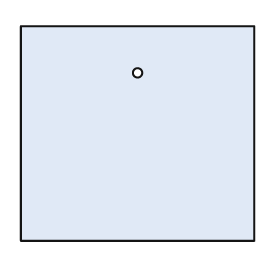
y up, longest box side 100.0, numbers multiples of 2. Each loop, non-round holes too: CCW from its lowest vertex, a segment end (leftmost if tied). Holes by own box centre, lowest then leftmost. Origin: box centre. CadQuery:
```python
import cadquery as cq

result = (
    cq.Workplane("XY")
    .moveTo(-50.0, -46.0)
    .lineTo(50.0, -46.0)
    .lineTo(50.0, 46.0)
    .lineTo(-50.0, 46.0)
    .close()
    .moveTo(0.0, 26.0)
    .circle(2.0)
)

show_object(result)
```